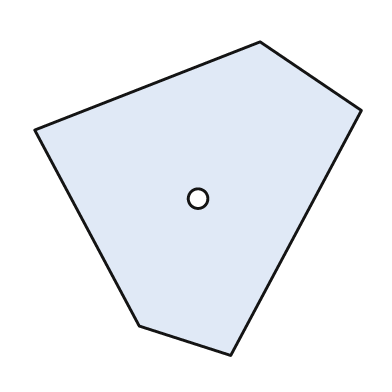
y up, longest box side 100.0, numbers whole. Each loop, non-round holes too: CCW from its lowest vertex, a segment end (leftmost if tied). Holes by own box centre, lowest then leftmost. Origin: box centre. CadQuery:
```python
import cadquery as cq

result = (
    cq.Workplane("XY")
    .moveTo(10.0, -48.0)
    .lineTo(50.0, 27.0)
    .lineTo(19.0, 48.0)
    .lineTo(-50.0, 21.0)
    .lineTo(-18.0, -39.0)
    .close()
    .moveTo(0.0, 0.0)
    .circle(3.0)
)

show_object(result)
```